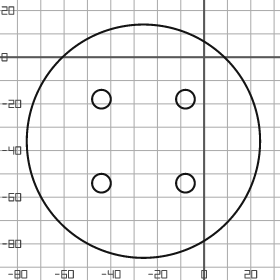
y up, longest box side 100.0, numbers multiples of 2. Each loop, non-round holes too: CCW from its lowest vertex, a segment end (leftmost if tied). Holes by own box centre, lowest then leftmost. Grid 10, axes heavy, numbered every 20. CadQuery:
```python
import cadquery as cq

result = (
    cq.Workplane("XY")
    .moveTo(-26.0, -36.0)
    .circle(50.0)
    .moveTo(-44.0, -54.0)
    .circle(4.0)
    .moveTo(-8.0, -54.0)
    .circle(4.0)
    .moveTo(-44.0, -18.0)
    .circle(4.0)
    .moveTo(-8.0, -18.0)
    .circle(4.0)
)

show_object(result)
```